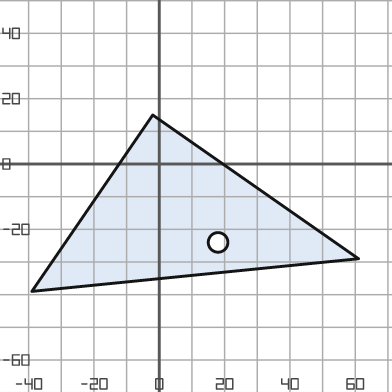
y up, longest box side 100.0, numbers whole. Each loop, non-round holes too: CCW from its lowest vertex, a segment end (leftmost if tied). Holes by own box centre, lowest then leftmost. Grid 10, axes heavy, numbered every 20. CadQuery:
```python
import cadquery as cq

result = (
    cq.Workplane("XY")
    .moveTo(-39.0, -39.0)
    .lineTo(61.0, -29.0)
    .lineTo(-2.0, 15.0)
    .close()
    .moveTo(18.0, -24.0)
    .circle(3.0)
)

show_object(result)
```